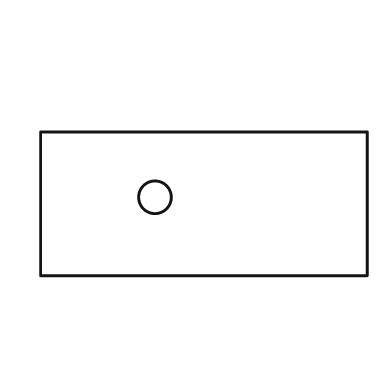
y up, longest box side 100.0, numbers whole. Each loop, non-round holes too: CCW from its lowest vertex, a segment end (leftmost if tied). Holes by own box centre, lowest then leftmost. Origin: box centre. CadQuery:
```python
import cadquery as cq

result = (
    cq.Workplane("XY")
    .moveTo(-50.0, -22.0)
    .lineTo(50.0, -22.0)
    .lineTo(50.0, 22.0)
    .lineTo(-50.0, 22.0)
    .close()
    .moveTo(-15.0, 2.0)
    .circle(5.0)
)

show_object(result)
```